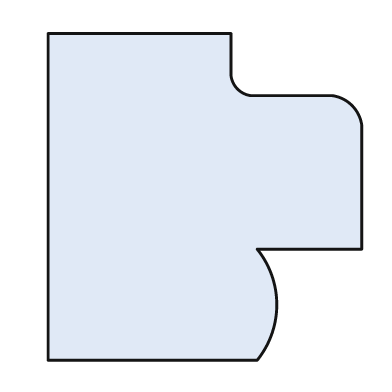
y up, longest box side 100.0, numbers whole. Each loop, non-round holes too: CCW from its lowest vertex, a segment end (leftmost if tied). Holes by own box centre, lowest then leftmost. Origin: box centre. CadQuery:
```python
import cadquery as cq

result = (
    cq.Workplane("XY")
    .moveTo(-48.0, -50.0)
    .lineTo(16.0, -50.0)
    .threePointArc((22.0, -33.0), (16.0, -16.0))
    .lineTo(48.0, -16.0)
    .lineTo(48.0, 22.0)
    .threePointArc((45.0, 28.0), (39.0, 31.0))
    .lineTo(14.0, 31.0)
    .threePointArc((10.0, 33.0), (8.0, 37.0))
    .lineTo(8.0, 50.0)
    .lineTo(-48.0, 50.0)
    .close()
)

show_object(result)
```